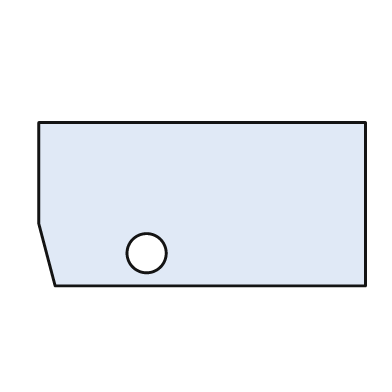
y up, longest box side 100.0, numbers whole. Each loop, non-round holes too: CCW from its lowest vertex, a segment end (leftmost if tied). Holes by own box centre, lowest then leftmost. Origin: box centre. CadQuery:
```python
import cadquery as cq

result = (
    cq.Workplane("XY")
    .moveTo(-45.0, -25.0)
    .lineTo(50.0, -25.0)
    .lineTo(50.0, 25.0)
    .lineTo(-50.0, 25.0)
    .lineTo(-50.0, -6.0)
    .close()
    .moveTo(-17.0, -15.0)
    .circle(6.0)
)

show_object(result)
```